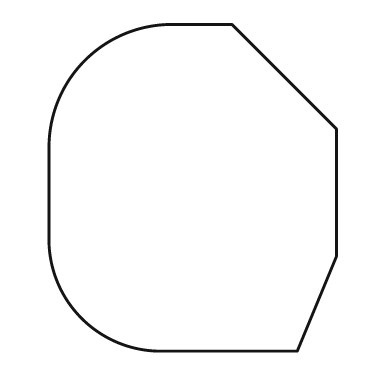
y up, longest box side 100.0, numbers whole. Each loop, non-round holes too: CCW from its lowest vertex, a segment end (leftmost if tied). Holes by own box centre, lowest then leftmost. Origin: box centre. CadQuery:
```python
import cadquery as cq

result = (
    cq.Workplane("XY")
    .moveTo(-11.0, -50.0)
    .lineTo(32.0, -50.0)
    .lineTo(44.0, -21.0)
    .lineTo(44.0, 18.0)
    .lineTo(12.0, 50.0)
    .lineTo(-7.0, 50.0)
    .threePointArc((-33.0, 39.0), (-44.0, 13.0))
    .lineTo(-44.0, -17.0)
    .threePointArc((-34.0, -40.0), (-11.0, -50.0))
    .close()
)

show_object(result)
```